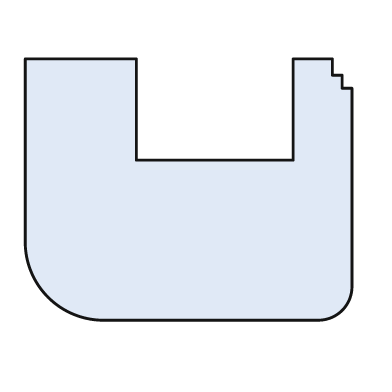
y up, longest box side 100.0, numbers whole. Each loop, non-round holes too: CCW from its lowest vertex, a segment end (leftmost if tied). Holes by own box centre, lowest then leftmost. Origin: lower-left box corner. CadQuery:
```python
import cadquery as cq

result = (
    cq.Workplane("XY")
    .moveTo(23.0, 0.0)
    .lineTo(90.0, 0.0)
    .threePointArc((97.0, 3.0), (100.0, 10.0))
    .lineTo(100.0, 71.0)
    .lineTo(97.0, 71.0)
    .lineTo(97.0, 75.0)
    .lineTo(94.0, 75.0)
    .lineTo(94.0, 80.0)
    .lineTo(82.0, 80.0)
    .lineTo(82.0, 49.0)
    .lineTo(34.0, 49.0)
    .lineTo(34.0, 80.0)
    .lineTo(0.0, 80.0)
    .lineTo(0.0, 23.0)
    .threePointArc((7.0, 7.0), (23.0, 0.0))
    .close()
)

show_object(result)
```